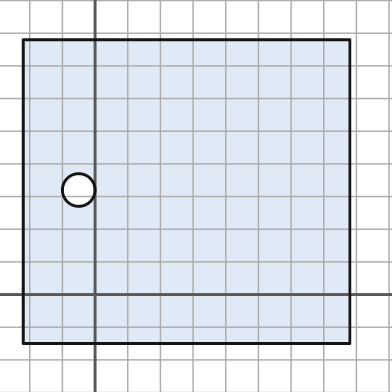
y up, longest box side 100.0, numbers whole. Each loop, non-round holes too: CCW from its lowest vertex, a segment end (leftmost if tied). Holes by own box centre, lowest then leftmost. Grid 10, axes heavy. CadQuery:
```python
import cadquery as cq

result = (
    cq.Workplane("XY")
    .moveTo(-22.0, -15.0)
    .lineTo(78.0, -15.0)
    .lineTo(78.0, 78.0)
    .lineTo(-22.0, 78.0)
    .close()
    .moveTo(-5.0, 32.0)
    .circle(5.0)
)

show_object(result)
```